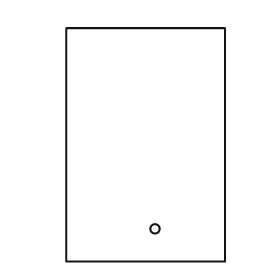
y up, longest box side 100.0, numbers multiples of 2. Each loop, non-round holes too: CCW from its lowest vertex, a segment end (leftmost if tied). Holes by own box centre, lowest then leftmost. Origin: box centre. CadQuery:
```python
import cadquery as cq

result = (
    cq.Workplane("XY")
    .moveTo(-34.0, -50.0)
    .lineTo(34.0, -50.0)
    .lineTo(34.0, 50.0)
    .lineTo(-34.0, 50.0)
    .close()
    .moveTo(4.0, -36.0)
    .circle(2.0)
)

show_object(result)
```